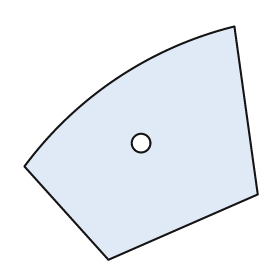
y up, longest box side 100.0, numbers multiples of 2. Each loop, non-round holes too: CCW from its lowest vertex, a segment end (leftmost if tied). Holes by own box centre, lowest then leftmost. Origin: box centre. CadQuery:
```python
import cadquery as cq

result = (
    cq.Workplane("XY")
    .moveTo(-14.0, -50.0)
    .lineTo(50.0, -22.0)
    .lineTo(40.0, 50.0)
    .threePointArc((-10.0, 28.0), (-50.0, -10.0))
    .close()
    .moveTo(0.0, 0.0)
    .circle(4.0)
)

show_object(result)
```